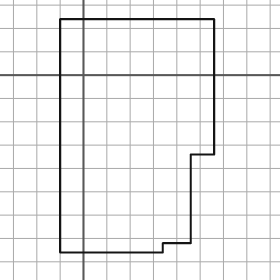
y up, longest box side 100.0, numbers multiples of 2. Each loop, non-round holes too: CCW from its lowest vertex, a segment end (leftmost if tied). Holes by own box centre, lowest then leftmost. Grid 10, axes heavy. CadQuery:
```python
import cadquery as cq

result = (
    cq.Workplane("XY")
    .moveTo(-10.0, -76.0)
    .lineTo(34.0, -76.0)
    .lineTo(34.0, -72.0)
    .lineTo(46.0, -72.0)
    .lineTo(46.0, -34.0)
    .lineTo(56.0, -34.0)
    .lineTo(56.0, 24.0)
    .lineTo(-10.0, 24.0)
    .close()
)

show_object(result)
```